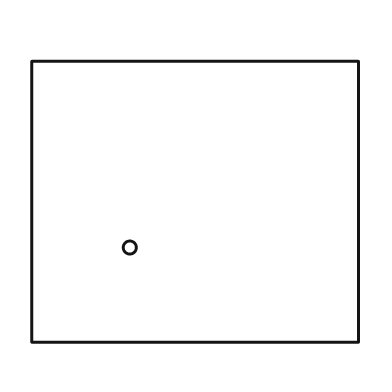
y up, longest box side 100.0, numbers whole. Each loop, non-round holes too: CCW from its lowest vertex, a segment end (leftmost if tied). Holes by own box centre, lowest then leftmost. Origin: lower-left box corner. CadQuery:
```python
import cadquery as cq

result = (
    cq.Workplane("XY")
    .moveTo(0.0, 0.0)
    .lineTo(100.0, 0.0)
    .lineTo(100.0, 86.0)
    .lineTo(0.0, 86.0)
    .close()
    .moveTo(30.0, 29.0)
    .circle(2.0)
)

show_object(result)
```